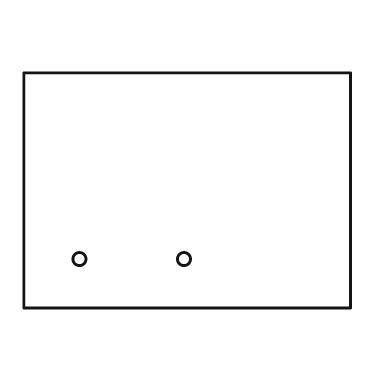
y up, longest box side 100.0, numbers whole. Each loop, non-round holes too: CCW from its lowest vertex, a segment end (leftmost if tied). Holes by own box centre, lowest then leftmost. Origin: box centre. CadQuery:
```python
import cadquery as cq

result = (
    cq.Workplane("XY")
    .moveTo(-50.0, -36.0)
    .lineTo(50.0, -36.0)
    .lineTo(50.0, 36.0)
    .lineTo(-50.0, 36.0)
    .close()
    .moveTo(-33.0, -21.0)
    .circle(2.0)
    .moveTo(-1.0, -21.0)
    .circle(2.0)
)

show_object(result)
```